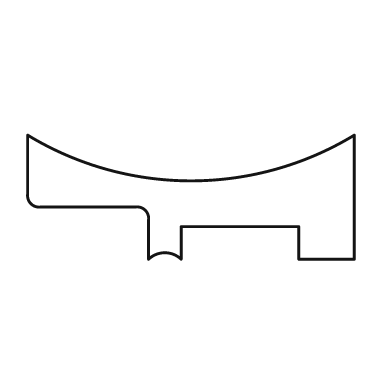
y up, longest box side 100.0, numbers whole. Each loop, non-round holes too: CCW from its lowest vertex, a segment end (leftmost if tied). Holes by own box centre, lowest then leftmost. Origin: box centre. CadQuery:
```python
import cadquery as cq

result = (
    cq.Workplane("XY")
    .moveTo(-13.0, -19.0)
    .threePointArc((-8.0, -17.0), (-3.0, -19.0))
    .lineTo(-3.0, -9.0)
    .lineTo(33.0, -9.0)
    .lineTo(33.0, -19.0)
    .lineTo(50.0, -19.0)
    .lineTo(50.0, 19.0)
    .threePointArc((0.0, 5.0), (-50.0, 19.0))
    .lineTo(-50.0, 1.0)
    .threePointArc((-49.0, -2.0), (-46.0, -3.0))
    .lineTo(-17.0, -3.0)
    .threePointArc((-14.0, -4.0), (-13.0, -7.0))
    .close()
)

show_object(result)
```